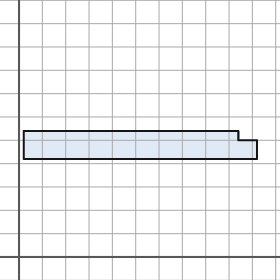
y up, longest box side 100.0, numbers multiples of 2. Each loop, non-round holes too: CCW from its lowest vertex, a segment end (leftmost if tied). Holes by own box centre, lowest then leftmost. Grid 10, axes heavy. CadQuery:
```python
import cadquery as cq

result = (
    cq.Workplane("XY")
    .moveTo(2.0, 42.0)
    .lineTo(102.0, 42.0)
    .lineTo(102.0, 50.0)
    .lineTo(94.0, 50.0)
    .lineTo(94.0, 54.0)
    .lineTo(2.0, 54.0)
    .close()
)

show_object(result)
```